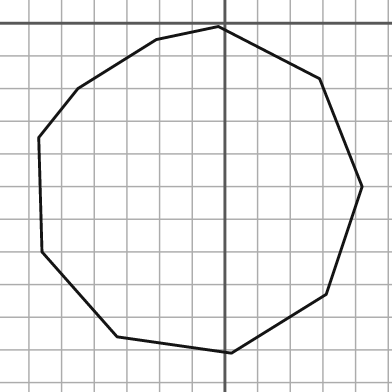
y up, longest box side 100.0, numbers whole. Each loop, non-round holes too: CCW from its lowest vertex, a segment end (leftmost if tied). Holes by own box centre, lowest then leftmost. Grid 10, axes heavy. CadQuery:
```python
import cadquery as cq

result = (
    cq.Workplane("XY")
    .moveTo(2.0, -101.0)
    .lineTo(31.0, -83.0)
    .lineTo(42.0, -50.0)
    .lineTo(29.0, -17.0)
    .lineTo(-2.0, -1.0)
    .lineTo(-21.0, -5.0)
    .lineTo(-45.0, -20.0)
    .lineTo(-57.0, -35.0)
    .lineTo(-56.0, -70.0)
    .lineTo(-33.0, -96.0)
    .close()
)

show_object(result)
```